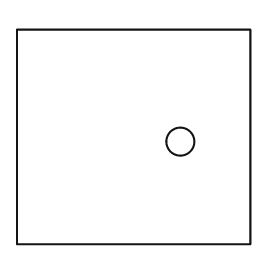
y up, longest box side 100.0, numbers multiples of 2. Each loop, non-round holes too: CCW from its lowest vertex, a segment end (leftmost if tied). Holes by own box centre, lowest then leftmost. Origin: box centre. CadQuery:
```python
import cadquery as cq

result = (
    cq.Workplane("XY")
    .moveTo(-50.0, -46.0)
    .lineTo(50.0, -46.0)
    .lineTo(50.0, 46.0)
    .lineTo(-50.0, 46.0)
    .close()
    .moveTo(20.0, -2.0)
    .circle(6.0)
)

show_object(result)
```